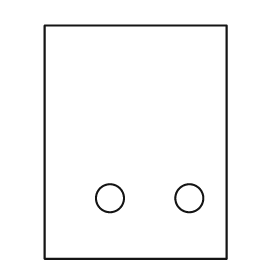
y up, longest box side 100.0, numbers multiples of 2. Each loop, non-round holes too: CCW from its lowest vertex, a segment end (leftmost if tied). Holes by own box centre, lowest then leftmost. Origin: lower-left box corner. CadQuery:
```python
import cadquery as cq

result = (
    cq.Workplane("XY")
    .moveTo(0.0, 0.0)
    .lineTo(78.0, 0.0)
    .lineTo(78.0, 100.0)
    .lineTo(0.0, 100.0)
    .close()
    .moveTo(28.0, 26.0)
    .circle(6.0)
    .moveTo(62.0, 26.0)
    .circle(6.0)
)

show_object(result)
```